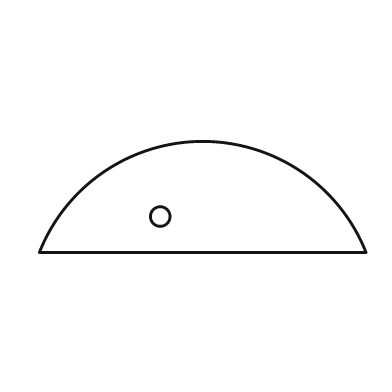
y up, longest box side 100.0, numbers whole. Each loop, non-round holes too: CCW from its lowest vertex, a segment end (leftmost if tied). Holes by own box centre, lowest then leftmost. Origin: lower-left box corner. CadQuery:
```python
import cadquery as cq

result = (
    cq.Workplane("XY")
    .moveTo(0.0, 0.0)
    .lineTo(100.0, 0.0)
    .threePointArc((50.0, 34.0), (0.0, 0.0))
    .close()
    .moveTo(37.0, 11.0)
    .circle(3.0)
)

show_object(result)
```